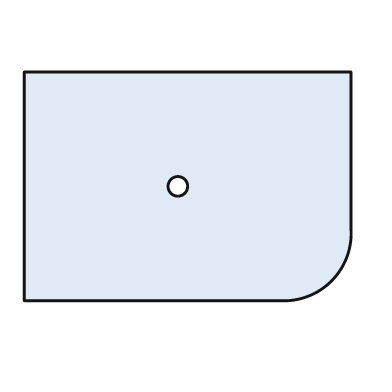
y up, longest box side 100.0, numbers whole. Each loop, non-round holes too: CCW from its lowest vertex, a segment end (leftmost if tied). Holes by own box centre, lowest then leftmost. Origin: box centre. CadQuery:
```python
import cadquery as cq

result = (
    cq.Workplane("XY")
    .moveTo(-50.0, -35.0)
    .lineTo(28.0, -35.0)
    .threePointArc((44.0, -29.0), (50.0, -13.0))
    .lineTo(50.0, 35.0)
    .lineTo(-50.0, 35.0)
    .close()
    .moveTo(-3.0, 0.0)
    .circle(3.0)
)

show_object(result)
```